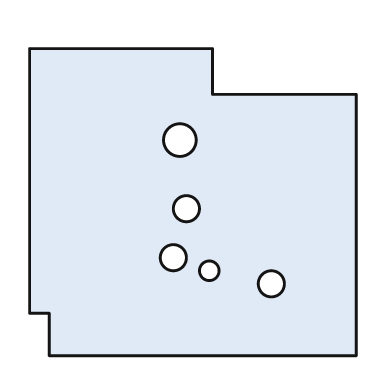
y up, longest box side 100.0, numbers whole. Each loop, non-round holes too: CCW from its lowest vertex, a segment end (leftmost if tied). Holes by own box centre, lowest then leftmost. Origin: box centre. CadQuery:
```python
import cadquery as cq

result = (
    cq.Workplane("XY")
    .moveTo(-44.0, -47.0)
    .lineTo(50.0, -47.0)
    .lineTo(50.0, 33.0)
    .lineTo(6.0, 33.0)
    .lineTo(6.0, 47.0)
    .lineTo(-50.0, 47.0)
    .lineTo(-50.0, -34.0)
    .lineTo(-44.0, -34.0)
    .close()
    .moveTo(24.0, -25.0)
    .circle(4.0)
    .moveTo(5.0, -21.0)
    .circle(3.0)
    .moveTo(-6.0, -17.0)
    .circle(4.0)
    .moveTo(-2.0, -2.0)
    .circle(4.0)
    .moveTo(-4.0, 19.0)
    .circle(5.0)
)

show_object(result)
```